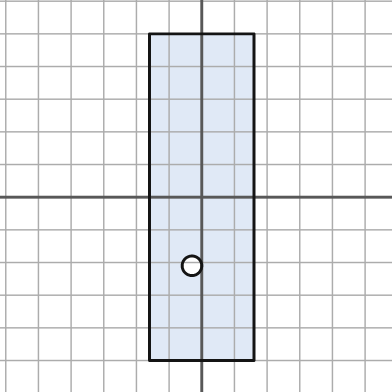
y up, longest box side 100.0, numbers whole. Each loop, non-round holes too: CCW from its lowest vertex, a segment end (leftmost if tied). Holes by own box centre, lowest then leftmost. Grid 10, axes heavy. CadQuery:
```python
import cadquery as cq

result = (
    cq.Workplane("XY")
    .moveTo(-16.0, -50.0)
    .lineTo(16.0, -50.0)
    .lineTo(16.0, 50.0)
    .lineTo(-16.0, 50.0)
    .close()
    .moveTo(-3.0, -21.0)
    .circle(3.0)
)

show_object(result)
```